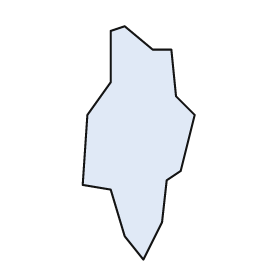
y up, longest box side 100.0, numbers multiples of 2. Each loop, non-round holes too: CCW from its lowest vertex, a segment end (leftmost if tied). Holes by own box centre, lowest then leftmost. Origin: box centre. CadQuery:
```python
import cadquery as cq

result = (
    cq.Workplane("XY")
    .moveTo(2.0, -50.0)
    .lineTo(10.0, -34.0)
    .lineTo(12.0, -16.0)
    .lineTo(18.0, -12.0)
    .lineTo(24.0, 12.0)
    .lineTo(16.0, 20.0)
    .lineTo(14.0, 40.0)
    .lineTo(6.0, 40.0)
    .lineTo(-6.0, 50.0)
    .lineTo(-12.0, 48.0)
    .lineTo(-12.0, 26.0)
    .lineTo(-22.0, 12.0)
    .lineTo(-24.0, -18.0)
    .lineTo(-12.0, -20.0)
    .lineTo(-6.0, -40.0)
    .close()
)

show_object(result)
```